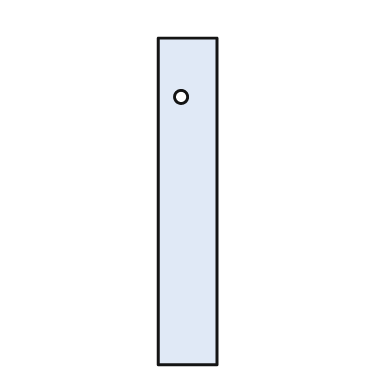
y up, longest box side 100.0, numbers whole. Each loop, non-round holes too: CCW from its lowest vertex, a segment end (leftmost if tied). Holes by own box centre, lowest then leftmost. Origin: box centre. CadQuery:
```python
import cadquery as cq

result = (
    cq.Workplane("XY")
    .moveTo(-9.0, -50.0)
    .lineTo(9.0, -50.0)
    .lineTo(9.0, 50.0)
    .lineTo(-9.0, 50.0)
    .close()
    .moveTo(-2.0, 32.0)
    .circle(2.0)
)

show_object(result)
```